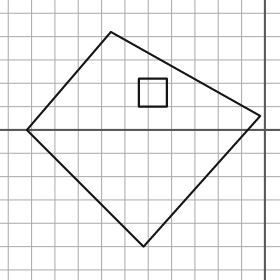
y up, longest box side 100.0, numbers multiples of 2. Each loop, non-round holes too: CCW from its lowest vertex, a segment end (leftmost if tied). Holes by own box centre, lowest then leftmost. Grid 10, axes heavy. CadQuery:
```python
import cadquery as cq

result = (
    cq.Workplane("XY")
    .moveTo(-52.0, -50.0)
    .lineTo(-2.0, 6.0)
    .lineTo(-66.0, 42.0)
    .lineTo(-102.0, 0.0)
    .close()
    .moveTo(-54.0, 10.0)
    .lineTo(-42.0, 10.0)
    .lineTo(-42.0, 22.0)
    .lineTo(-54.0, 22.0)
    .close()
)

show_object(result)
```